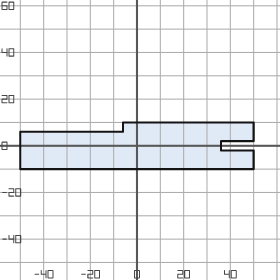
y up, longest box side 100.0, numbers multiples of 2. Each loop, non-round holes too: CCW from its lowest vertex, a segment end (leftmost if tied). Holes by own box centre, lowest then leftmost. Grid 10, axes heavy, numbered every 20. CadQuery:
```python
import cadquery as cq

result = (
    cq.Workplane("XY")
    .moveTo(-50.0, -10.0)
    .lineTo(50.0, -10.0)
    .lineTo(50.0, -2.0)
    .lineTo(36.0, -2.0)
    .lineTo(36.0, 2.0)
    .lineTo(50.0, 2.0)
    .lineTo(50.0, 10.0)
    .lineTo(-6.0, 10.0)
    .lineTo(-6.0, 6.0)
    .lineTo(-50.0, 6.0)
    .close()
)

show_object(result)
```